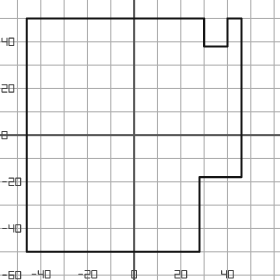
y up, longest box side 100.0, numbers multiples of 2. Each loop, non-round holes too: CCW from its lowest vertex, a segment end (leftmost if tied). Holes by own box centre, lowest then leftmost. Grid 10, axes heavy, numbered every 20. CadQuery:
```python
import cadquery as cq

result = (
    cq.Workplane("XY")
    .moveTo(-46.0, -50.0)
    .lineTo(28.0, -50.0)
    .lineTo(28.0, -18.0)
    .lineTo(46.0, -18.0)
    .lineTo(46.0, 50.0)
    .lineTo(40.0, 50.0)
    .lineTo(40.0, 38.0)
    .lineTo(30.0, 38.0)
    .lineTo(30.0, 50.0)
    .lineTo(-46.0, 50.0)
    .close()
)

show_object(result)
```